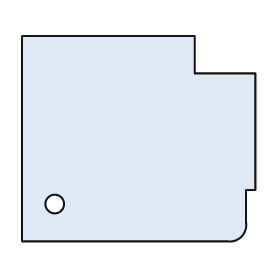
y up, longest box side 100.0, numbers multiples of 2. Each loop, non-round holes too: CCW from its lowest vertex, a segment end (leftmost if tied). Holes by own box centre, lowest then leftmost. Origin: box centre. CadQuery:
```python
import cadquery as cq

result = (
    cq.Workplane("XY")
    .moveTo(-50.0, -44.0)
    .lineTo(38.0, -44.0)
    .threePointArc((44.0, -42.0), (46.0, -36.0))
    .lineTo(46.0, -22.0)
    .lineTo(50.0, -22.0)
    .lineTo(50.0, 28.0)
    .lineTo(24.0, 28.0)
    .lineTo(24.0, 44.0)
    .lineTo(-50.0, 44.0)
    .close()
    .moveTo(-36.0, -28.0)
    .circle(4.0)
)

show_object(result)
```